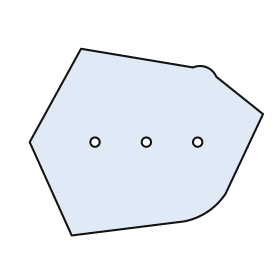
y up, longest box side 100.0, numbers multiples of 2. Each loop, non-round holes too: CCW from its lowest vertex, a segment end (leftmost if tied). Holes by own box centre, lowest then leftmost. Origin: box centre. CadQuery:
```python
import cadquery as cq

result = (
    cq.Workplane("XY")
    .moveTo(-32.0, -40.0)
    .lineTo(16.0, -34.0)
    .threePointArc((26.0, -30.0), (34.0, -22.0))
    .lineTo(50.0, 12.0)
    .lineTo(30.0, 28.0)
    .threePointArc((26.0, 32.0), (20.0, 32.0))
    .lineTo(-28.0, 40.0)
    .lineTo(-50.0, 0.0)
    .close()
    .moveTo(-22.0, 0.0)
    .circle(2.0)
    .moveTo(0.0, 0.0)
    .circle(2.0)
    .moveTo(22.0, 0.0)
    .circle(2.0)
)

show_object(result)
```